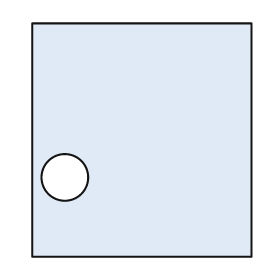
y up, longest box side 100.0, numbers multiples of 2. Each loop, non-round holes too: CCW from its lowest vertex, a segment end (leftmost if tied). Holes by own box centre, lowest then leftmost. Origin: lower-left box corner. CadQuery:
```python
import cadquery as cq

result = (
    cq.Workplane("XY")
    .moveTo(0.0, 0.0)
    .lineTo(94.0, 0.0)
    .lineTo(94.0, 100.0)
    .lineTo(0.0, 100.0)
    .close()
    .moveTo(14.0, 34.0)
    .circle(10.0)
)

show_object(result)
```